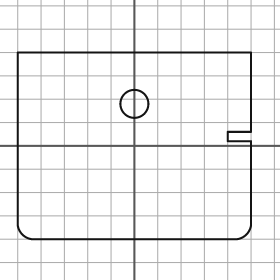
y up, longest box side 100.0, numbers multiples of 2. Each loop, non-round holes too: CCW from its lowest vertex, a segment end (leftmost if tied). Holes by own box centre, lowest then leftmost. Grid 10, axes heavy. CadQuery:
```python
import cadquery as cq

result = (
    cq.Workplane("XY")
    .moveTo(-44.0, -40.0)
    .lineTo(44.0, -40.0)
    .threePointArc((48.0, -38.0), (50.0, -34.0))
    .lineTo(50.0, 2.0)
    .lineTo(40.0, 2.0)
    .lineTo(40.0, 6.0)
    .lineTo(50.0, 6.0)
    .lineTo(50.0, 40.0)
    .lineTo(-50.0, 40.0)
    .lineTo(-50.0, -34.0)
    .threePointArc((-48.0, -38.0), (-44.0, -40.0))
    .close()
    .moveTo(0.0, 18.0)
    .circle(6.0)
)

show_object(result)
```